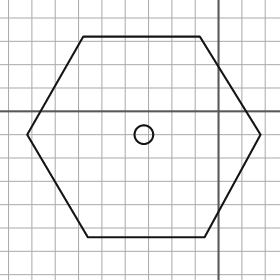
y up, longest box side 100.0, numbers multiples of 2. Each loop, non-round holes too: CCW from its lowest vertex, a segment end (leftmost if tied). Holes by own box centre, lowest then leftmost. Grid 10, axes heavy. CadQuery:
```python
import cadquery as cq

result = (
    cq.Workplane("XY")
    .moveTo(-56.0, -54.0)
    .lineTo(-6.0, -54.0)
    .lineTo(18.0, -10.0)
    .lineTo(-8.0, 32.0)
    .lineTo(-58.0, 32.0)
    .lineTo(-82.0, -10.0)
    .close()
    .moveTo(-32.0, -10.0)
    .circle(4.0)
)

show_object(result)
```